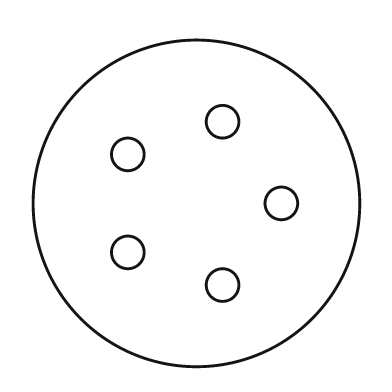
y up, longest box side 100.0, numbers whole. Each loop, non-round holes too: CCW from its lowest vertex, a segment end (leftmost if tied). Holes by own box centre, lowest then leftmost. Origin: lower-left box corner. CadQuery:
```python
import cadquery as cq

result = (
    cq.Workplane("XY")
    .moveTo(50.0, 50.0)
    .circle(50.0)
    .moveTo(58.0, 25.0)
    .circle(5.0)
    .moveTo(29.0, 35.0)
    .circle(5.0)
    .moveTo(76.0, 50.0)
    .circle(5.0)
    .moveTo(29.0, 65.0)
    .circle(5.0)
    .moveTo(58.0, 75.0)
    .circle(5.0)
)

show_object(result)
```